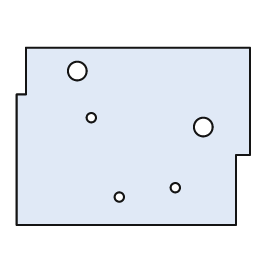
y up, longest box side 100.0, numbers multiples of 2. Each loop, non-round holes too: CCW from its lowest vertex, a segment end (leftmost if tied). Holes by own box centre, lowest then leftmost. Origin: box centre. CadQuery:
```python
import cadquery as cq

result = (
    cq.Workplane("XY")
    .moveTo(-50.0, -38.0)
    .lineTo(44.0, -38.0)
    .lineTo(44.0, -8.0)
    .lineTo(50.0, -8.0)
    .lineTo(50.0, 38.0)
    .lineTo(-46.0, 38.0)
    .lineTo(-46.0, 18.0)
    .lineTo(-50.0, 18.0)
    .close()
    .moveTo(-6.0, -26.0)
    .circle(2.0)
    .moveTo(18.0, -22.0)
    .circle(2.0)
    .moveTo(30.0, 4.0)
    .circle(4.0)
    .moveTo(-18.0, 8.0)
    .circle(2.0)
    .moveTo(-24.0, 28.0)
    .circle(4.0)
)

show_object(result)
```